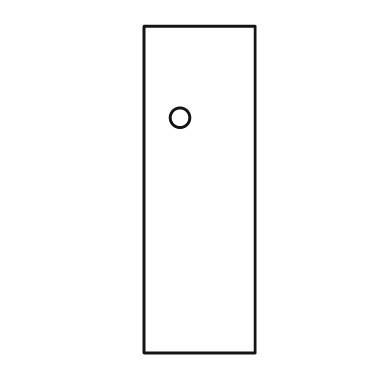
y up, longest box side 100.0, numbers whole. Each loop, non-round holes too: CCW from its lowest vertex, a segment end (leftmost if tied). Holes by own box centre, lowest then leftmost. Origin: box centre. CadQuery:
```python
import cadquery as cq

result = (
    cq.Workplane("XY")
    .moveTo(-17.0, -50.0)
    .lineTo(17.0, -50.0)
    .lineTo(17.0, 50.0)
    .lineTo(-17.0, 50.0)
    .close()
    .moveTo(-6.0, 22.0)
    .circle(3.0)
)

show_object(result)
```